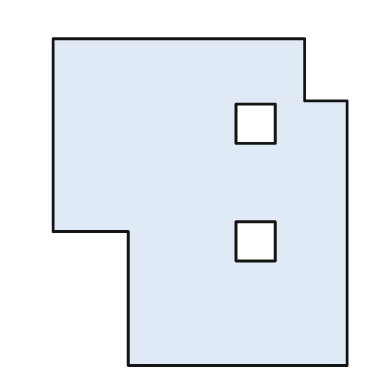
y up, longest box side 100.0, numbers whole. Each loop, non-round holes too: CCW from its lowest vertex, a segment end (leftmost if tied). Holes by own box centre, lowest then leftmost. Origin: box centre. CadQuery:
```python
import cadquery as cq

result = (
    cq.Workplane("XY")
    .moveTo(-22.0, -50.0)
    .lineTo(45.0, -50.0)
    .lineTo(45.0, 31.0)
    .lineTo(32.0, 31.0)
    .lineTo(32.0, 50.0)
    .lineTo(-45.0, 50.0)
    .lineTo(-45.0, -9.0)
    .lineTo(-22.0, -9.0)
    .close()
    .moveTo(11.0, -18.0)
    .lineTo(23.0, -18.0)
    .lineTo(23.0, -6.0)
    .lineTo(11.0, -6.0)
    .close()
    .moveTo(11.0, 18.0)
    .lineTo(23.0, 18.0)
    .lineTo(23.0, 30.0)
    .lineTo(11.0, 30.0)
    .close()
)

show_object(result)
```